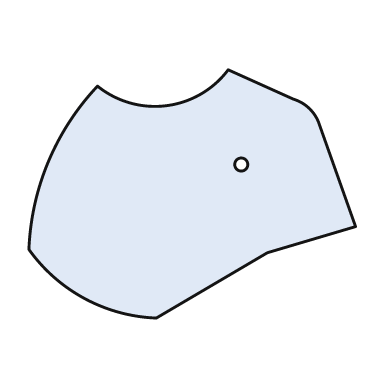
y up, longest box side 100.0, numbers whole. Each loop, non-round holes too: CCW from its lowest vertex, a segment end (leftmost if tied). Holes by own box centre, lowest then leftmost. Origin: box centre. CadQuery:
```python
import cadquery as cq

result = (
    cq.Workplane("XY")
    .moveTo(-11.0, -38.0)
    .lineTo(23.0, -18.0)
    .lineTo(50.0, -10.0)
    .lineTo(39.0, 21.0)
    .threePointArc((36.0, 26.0), (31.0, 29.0))
    .lineTo(11.0, 38.0)
    .threePointArc((-8.0, 27.0), (-29.0, 33.0))
    .threePointArc((-44.0, 10.0), (-50.0, -17.0))
    .threePointArc((-33.0, -32.0), (-11.0, -38.0))
    .close()
    .moveTo(15.0, 9.0)
    .circle(2.0)
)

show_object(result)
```